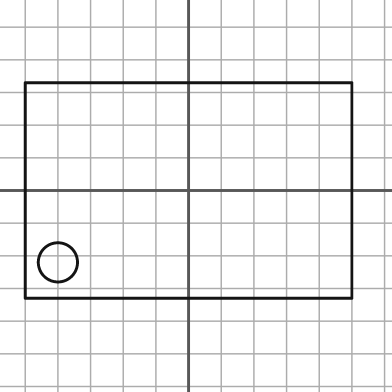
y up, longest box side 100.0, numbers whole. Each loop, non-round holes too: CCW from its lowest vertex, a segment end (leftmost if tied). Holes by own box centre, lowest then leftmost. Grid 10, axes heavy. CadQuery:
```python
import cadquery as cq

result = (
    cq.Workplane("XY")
    .moveTo(-50.0, -33.0)
    .lineTo(50.0, -33.0)
    .lineTo(50.0, 33.0)
    .lineTo(-50.0, 33.0)
    .close()
    .moveTo(-40.0, -22.0)
    .circle(6.0)
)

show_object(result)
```